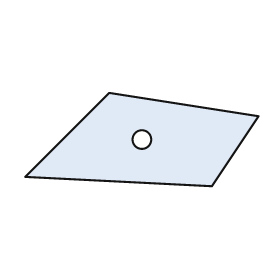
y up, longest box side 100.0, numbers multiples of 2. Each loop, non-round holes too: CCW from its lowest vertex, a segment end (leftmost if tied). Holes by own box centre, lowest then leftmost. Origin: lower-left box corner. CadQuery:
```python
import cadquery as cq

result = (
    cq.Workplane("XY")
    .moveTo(80.0, 0.0)
    .lineTo(100.0, 30.0)
    .lineTo(36.0, 40.0)
    .lineTo(0.0, 4.0)
    .close()
    .moveTo(50.0, 20.0)
    .circle(4.0)
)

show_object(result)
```